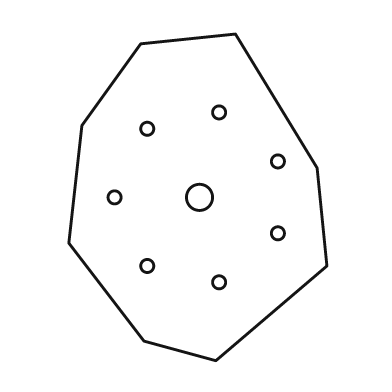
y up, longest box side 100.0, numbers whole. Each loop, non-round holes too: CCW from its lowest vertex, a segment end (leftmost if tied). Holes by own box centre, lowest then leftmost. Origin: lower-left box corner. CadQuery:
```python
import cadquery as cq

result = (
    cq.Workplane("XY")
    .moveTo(45.0, 0.0)
    .lineTo(79.0, 29.0)
    .lineTo(76.0, 59.0)
    .lineTo(51.0, 100.0)
    .lineTo(22.0, 97.0)
    .lineTo(4.0, 72.0)
    .lineTo(0.0, 36.0)
    .lineTo(23.0, 6.0)
    .close()
    .moveTo(46.0, 24.0)
    .circle(2.0)
    .moveTo(24.0, 29.0)
    .circle(2.0)
    .moveTo(64.0, 39.0)
    .circle(2.0)
    .moveTo(14.0, 50.0)
    .circle(2.0)
    .moveTo(40.0, 50.0)
    .circle(4.0)
    .moveTo(64.0, 61.0)
    .circle(2.0)
    .moveTo(24.0, 71.0)
    .circle(2.0)
    .moveTo(46.0, 76.0)
    .circle(2.0)
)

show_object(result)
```